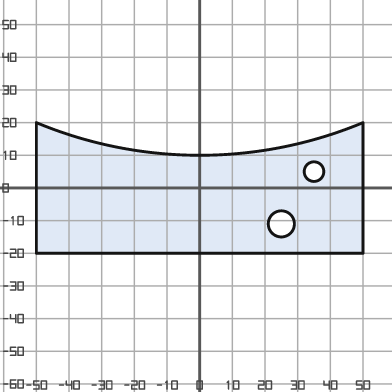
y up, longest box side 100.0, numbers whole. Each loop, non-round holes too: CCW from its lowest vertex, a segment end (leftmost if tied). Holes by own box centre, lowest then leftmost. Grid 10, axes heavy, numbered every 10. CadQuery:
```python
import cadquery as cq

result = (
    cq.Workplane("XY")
    .moveTo(-50.0, -20.0)
    .lineTo(50.0, -20.0)
    .lineTo(50.0, 20.0)
    .threePointArc((0.0, 10.0), (-50.0, 20.0))
    .close()
    .moveTo(25.0, -11.0)
    .circle(4.0)
    .moveTo(35.0, 5.0)
    .circle(3.0)
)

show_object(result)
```